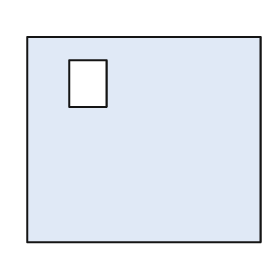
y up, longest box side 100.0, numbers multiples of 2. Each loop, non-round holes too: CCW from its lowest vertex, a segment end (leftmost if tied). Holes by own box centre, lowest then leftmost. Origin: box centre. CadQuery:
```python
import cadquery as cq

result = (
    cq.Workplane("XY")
    .moveTo(-50.0, -44.0)
    .lineTo(50.0, -44.0)
    .lineTo(50.0, 44.0)
    .lineTo(-50.0, 44.0)
    .close()
    .moveTo(-32.0, 14.0)
    .lineTo(-16.0, 14.0)
    .lineTo(-16.0, 34.0)
    .lineTo(-32.0, 34.0)
    .close()
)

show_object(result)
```